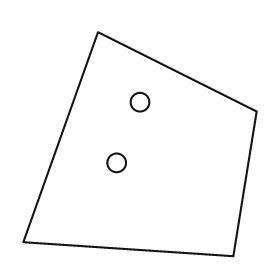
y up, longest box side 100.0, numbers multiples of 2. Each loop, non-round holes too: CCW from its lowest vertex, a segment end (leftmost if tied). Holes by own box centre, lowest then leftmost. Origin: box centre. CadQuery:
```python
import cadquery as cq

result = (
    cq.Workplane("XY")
    .moveTo(40.0, -48.0)
    .lineTo(50.0, 14.0)
    .lineTo(-18.0, 48.0)
    .lineTo(-50.0, -42.0)
    .close()
    .moveTo(-10.0, -8.0)
    .circle(4.0)
    .moveTo(0.0, 18.0)
    .circle(4.0)
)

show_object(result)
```